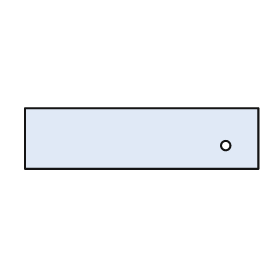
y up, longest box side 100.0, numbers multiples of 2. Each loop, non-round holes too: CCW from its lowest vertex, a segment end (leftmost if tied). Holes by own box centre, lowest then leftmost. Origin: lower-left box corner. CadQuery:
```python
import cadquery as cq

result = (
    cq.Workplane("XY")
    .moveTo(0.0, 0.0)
    .lineTo(100.0, 0.0)
    .lineTo(100.0, 26.0)
    .lineTo(0.0, 26.0)
    .close()
    .moveTo(86.0, 10.0)
    .circle(2.0)
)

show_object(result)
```